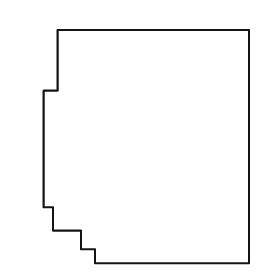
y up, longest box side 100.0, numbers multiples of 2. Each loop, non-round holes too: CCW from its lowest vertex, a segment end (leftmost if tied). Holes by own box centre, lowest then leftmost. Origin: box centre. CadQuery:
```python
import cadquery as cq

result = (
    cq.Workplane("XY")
    .moveTo(-22.0, -50.0)
    .lineTo(44.0, -50.0)
    .lineTo(44.0, 50.0)
    .lineTo(-38.0, 50.0)
    .lineTo(-38.0, 24.0)
    .lineTo(-44.0, 24.0)
    .lineTo(-44.0, -26.0)
    .lineTo(-40.0, -26.0)
    .lineTo(-40.0, -36.0)
    .lineTo(-28.0, -36.0)
    .lineTo(-28.0, -44.0)
    .lineTo(-22.0, -44.0)
    .close()
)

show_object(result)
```